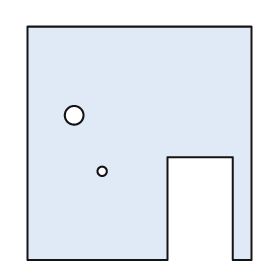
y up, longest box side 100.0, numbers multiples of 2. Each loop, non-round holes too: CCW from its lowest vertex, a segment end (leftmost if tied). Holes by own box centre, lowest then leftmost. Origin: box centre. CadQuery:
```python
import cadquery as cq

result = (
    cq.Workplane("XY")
    .moveTo(-48.0, -50.0)
    .lineTo(12.0, -50.0)
    .lineTo(12.0, -6.0)
    .lineTo(40.0, -6.0)
    .lineTo(40.0, -50.0)
    .lineTo(48.0, -50.0)
    .lineTo(48.0, 50.0)
    .lineTo(-48.0, 50.0)
    .close()
    .moveTo(-16.0, -12.0)
    .circle(2.0)
    .moveTo(-28.0, 12.0)
    .circle(4.0)
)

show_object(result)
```